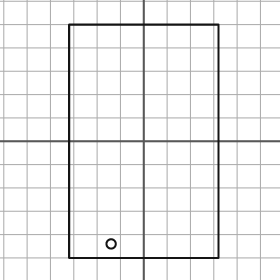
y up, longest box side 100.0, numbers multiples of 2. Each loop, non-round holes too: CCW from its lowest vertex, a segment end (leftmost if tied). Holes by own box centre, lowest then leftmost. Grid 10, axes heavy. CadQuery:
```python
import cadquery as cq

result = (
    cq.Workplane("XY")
    .moveTo(-32.0, -50.0)
    .lineTo(32.0, -50.0)
    .lineTo(32.0, 50.0)
    .lineTo(-32.0, 50.0)
    .close()
    .moveTo(-14.0, -44.0)
    .circle(2.0)
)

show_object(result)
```